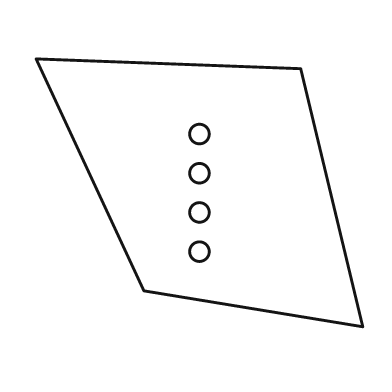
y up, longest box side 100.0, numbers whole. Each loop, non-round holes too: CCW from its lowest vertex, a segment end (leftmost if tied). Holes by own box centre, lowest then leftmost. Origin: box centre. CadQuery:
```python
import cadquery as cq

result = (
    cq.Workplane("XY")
    .moveTo(50.0, -41.0)
    .lineTo(31.0, 38.0)
    .lineTo(-50.0, 41.0)
    .lineTo(-17.0, -30.0)
    .close()
    .moveTo(0.0, -18.0)
    .circle(3.0)
    .moveTo(0.0, -6.0)
    .circle(3.0)
    .moveTo(0.0, 6.0)
    .circle(3.0)
    .moveTo(0.0, 18.0)
    .circle(3.0)
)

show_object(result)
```